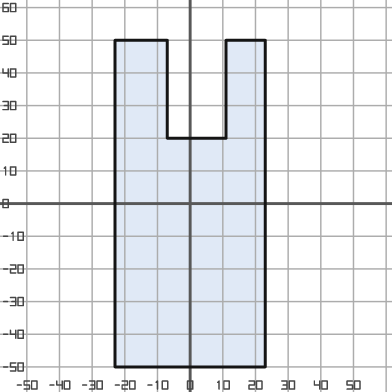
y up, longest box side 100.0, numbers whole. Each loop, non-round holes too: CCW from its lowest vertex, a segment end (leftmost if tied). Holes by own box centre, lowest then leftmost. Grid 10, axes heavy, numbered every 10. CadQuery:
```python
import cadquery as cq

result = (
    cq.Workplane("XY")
    .moveTo(-23.0, -50.0)
    .lineTo(23.0, -50.0)
    .lineTo(23.0, 50.0)
    .lineTo(11.0, 50.0)
    .lineTo(11.0, 20.0)
    .lineTo(-7.0, 20.0)
    .lineTo(-7.0, 50.0)
    .lineTo(-23.0, 50.0)
    .close()
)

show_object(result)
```